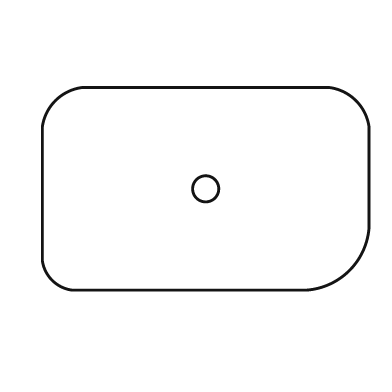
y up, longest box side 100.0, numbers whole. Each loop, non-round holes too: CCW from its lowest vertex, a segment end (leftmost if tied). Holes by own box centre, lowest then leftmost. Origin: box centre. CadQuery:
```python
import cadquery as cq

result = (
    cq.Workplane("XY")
    .moveTo(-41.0, -31.0)
    .lineTo(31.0, -31.0)
    .threePointArc((44.0, -25.0), (50.0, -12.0))
    .lineTo(50.0, 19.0)
    .threePointArc((46.0, 27.0), (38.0, 31.0))
    .lineTo(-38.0, 31.0)
    .threePointArc((-46.0, 27.0), (-50.0, 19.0))
    .lineTo(-50.0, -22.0)
    .threePointArc((-47.0, -28.0), (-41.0, -31.0))
    .close()
    .moveTo(0.0, 0.0)
    .circle(4.0)
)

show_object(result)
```